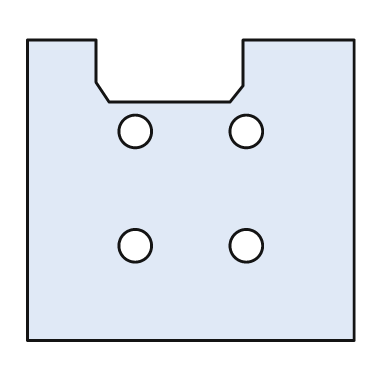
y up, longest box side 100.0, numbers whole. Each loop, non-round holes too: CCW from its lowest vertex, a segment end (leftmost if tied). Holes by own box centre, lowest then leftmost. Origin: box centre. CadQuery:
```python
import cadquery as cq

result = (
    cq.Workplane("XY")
    .moveTo(-50.0, -46.0)
    .lineTo(50.0, -46.0)
    .lineTo(50.0, 46.0)
    .lineTo(16.0, 46.0)
    .lineTo(16.0, 32.0)
    .lineTo(12.0, 27.0)
    .lineTo(-25.0, 27.0)
    .lineTo(-29.0, 33.0)
    .lineTo(-29.0, 46.0)
    .lineTo(-50.0, 46.0)
    .close()
    .moveTo(-17.0, -17.0)
    .circle(5.0)
    .moveTo(17.0, -17.0)
    .circle(5.0)
    .moveTo(-17.0, 18.0)
    .circle(5.0)
    .moveTo(17.0, 18.0)
    .circle(5.0)
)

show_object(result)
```